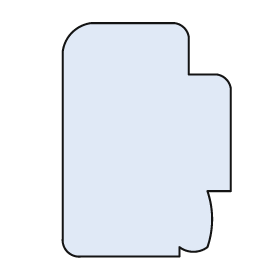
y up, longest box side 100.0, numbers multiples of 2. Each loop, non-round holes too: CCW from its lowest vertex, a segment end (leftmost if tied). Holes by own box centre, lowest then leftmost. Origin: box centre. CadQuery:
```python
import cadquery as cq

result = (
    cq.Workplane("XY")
    .moveTo(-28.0, -50.0)
    .lineTo(14.0, -50.0)
    .lineTo(14.0, -46.0)
    .threePointArc((20.0, -48.0), (26.0, -46.0))
    .threePointArc((28.0, -34.0), (26.0, -22.0))
    .lineTo(36.0, -22.0)
    .lineTo(36.0, 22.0)
    .threePointArc((34.0, 26.0), (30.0, 28.0))
    .lineTo(18.0, 28.0)
    .lineTo(18.0, 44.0)
    .threePointArc((16.0, 48.0), (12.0, 50.0))
    .lineTo(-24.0, 50.0)
    .threePointArc((-32.0, 46.0), (-36.0, 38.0))
    .lineTo(-36.0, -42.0)
    .threePointArc((-34.0, -48.0), (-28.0, -50.0))
    .close()
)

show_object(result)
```